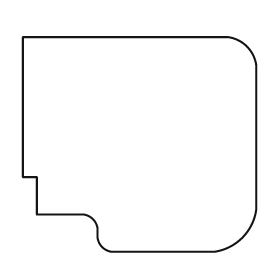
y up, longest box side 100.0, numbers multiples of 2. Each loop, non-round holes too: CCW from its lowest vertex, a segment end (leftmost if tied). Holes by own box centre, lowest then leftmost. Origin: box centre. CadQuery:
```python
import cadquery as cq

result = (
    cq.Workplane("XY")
    .moveTo(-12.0, -46.0)
    .lineTo(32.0, -46.0)
    .threePointArc((44.0, -40.0), (50.0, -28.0))
    .lineTo(50.0, 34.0)
    .threePointArc((46.0, 42.0), (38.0, 46.0))
    .lineTo(-50.0, 46.0)
    .lineTo(-50.0, -14.0)
    .lineTo(-44.0, -14.0)
    .lineTo(-44.0, -30.0)
    .lineTo(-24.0, -30.0)
    .threePointArc((-20.0, -32.0), (-18.0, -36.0))
    .lineTo(-18.0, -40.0)
    .threePointArc((-16.0, -44.0), (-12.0, -46.0))
    .close()
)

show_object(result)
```